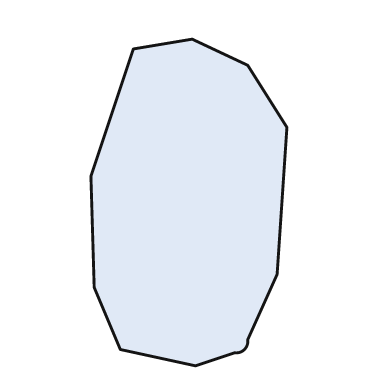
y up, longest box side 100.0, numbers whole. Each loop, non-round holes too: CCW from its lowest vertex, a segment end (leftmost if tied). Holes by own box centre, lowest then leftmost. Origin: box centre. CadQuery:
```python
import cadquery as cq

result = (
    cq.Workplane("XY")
    .moveTo(2.0, -50.0)
    .lineTo(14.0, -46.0)
    .threePointArc((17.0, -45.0), (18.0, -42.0))
    .lineTo(27.0, -22.0)
    .lineTo(30.0, 23.0)
    .lineTo(18.0, 42.0)
    .lineTo(1.0, 50.0)
    .lineTo(-17.0, 47.0)
    .lineTo(-30.0, 8.0)
    .lineTo(-29.0, -26.0)
    .lineTo(-21.0, -45.0)
    .close()
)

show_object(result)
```